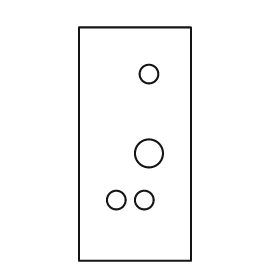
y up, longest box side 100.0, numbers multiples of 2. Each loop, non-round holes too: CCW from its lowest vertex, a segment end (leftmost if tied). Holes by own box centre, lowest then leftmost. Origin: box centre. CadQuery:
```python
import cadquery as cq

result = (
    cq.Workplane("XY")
    .moveTo(-24.0, -50.0)
    .lineTo(24.0, -50.0)
    .lineTo(24.0, 50.0)
    .lineTo(-24.0, 50.0)
    .close()
    .moveTo(-8.0, -24.0)
    .circle(4.0)
    .moveTo(4.0, -24.0)
    .circle(4.0)
    .moveTo(6.0, -4.0)
    .circle(6.0)
    .moveTo(6.0, 30.0)
    .circle(4.0)
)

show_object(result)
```